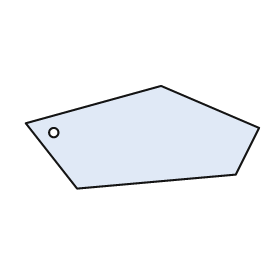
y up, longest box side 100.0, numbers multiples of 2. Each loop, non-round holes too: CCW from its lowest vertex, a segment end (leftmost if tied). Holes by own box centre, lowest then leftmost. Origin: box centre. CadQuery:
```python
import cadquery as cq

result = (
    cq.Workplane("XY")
    .moveTo(-28.0, -22.0)
    .lineTo(40.0, -16.0)
    .lineTo(50.0, 4.0)
    .lineTo(8.0, 22.0)
    .lineTo(-50.0, 6.0)
    .close()
    .moveTo(-38.0, 2.0)
    .circle(2.0)
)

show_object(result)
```